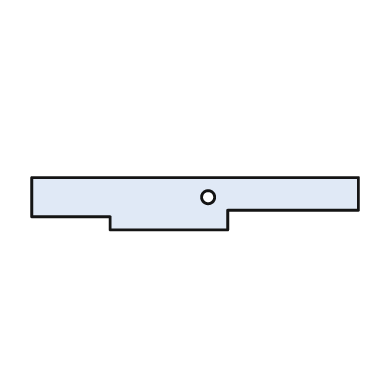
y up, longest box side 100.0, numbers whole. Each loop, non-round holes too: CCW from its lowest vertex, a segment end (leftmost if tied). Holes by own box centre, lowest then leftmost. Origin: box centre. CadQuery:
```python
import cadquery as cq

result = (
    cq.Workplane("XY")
    .moveTo(-26.0, -8.0)
    .lineTo(10.0, -8.0)
    .lineTo(10.0, -2.0)
    .lineTo(50.0, -2.0)
    .lineTo(50.0, 8.0)
    .lineTo(-50.0, 8.0)
    .lineTo(-50.0, -4.0)
    .lineTo(-26.0, -4.0)
    .close()
    .moveTo(4.0, 2.0)
    .circle(2.0)
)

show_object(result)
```